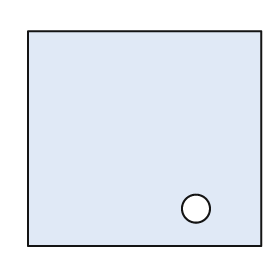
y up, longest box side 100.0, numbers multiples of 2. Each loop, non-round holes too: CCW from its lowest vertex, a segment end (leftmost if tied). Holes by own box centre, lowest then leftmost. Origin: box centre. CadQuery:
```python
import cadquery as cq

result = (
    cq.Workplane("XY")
    .moveTo(-50.0, -46.0)
    .lineTo(50.0, -46.0)
    .lineTo(50.0, 46.0)
    .lineTo(-50.0, 46.0)
    .close()
    .moveTo(22.0, -30.0)
    .circle(6.0)
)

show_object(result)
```